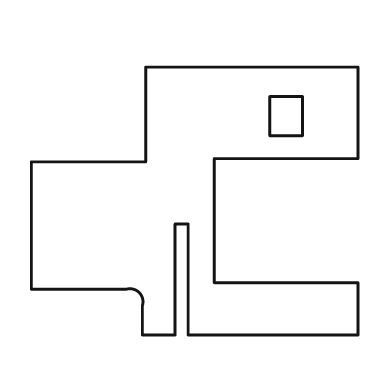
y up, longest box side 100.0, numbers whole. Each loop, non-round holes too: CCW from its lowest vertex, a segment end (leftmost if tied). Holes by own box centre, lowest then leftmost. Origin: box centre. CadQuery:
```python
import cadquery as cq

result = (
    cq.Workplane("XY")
    .moveTo(-16.0, -41.0)
    .lineTo(-6.0, -41.0)
    .lineTo(-6.0, -7.0)
    .lineTo(-2.0, -7.0)
    .lineTo(-2.0, -41.0)
    .lineTo(50.0, -41.0)
    .lineTo(50.0, -25.0)
    .lineTo(6.0, -25.0)
    .lineTo(6.0, 13.0)
    .lineTo(50.0, 13.0)
    .lineTo(50.0, 41.0)
    .lineTo(-15.0, 41.0)
    .lineTo(-15.0, 12.0)
    .lineTo(-50.0, 12.0)
    .lineTo(-50.0, -27.0)
    .lineTo(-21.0, -27.0)
    .threePointArc((-17.0, -28.0), (-16.0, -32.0))
    .close()
    .moveTo(23.0, 20.0)
    .lineTo(33.0, 20.0)
    .lineTo(33.0, 32.0)
    .lineTo(23.0, 32.0)
    .close()
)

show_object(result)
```